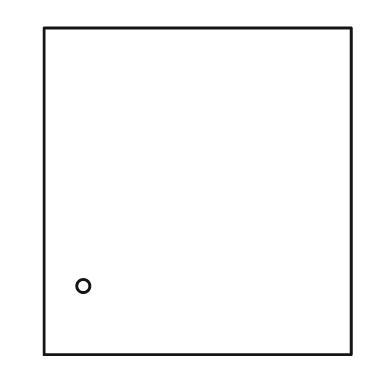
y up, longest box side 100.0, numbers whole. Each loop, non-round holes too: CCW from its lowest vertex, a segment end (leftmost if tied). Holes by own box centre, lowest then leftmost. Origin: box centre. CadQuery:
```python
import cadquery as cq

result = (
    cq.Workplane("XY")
    .moveTo(-47.0, -50.0)
    .lineTo(47.0, -50.0)
    .lineTo(47.0, 50.0)
    .lineTo(-47.0, 50.0)
    .close()
    .moveTo(-35.0, -29.0)
    .circle(2.0)
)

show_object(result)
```